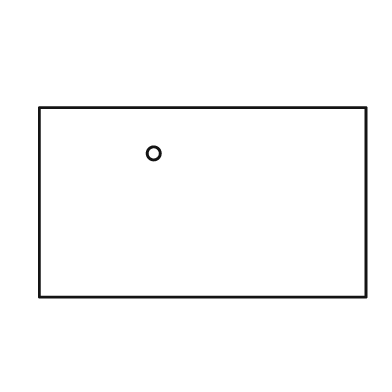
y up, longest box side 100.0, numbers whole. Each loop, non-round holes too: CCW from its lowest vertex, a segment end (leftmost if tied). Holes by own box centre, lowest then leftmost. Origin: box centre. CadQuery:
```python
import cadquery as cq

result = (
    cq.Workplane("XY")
    .moveTo(-50.0, -29.0)
    .lineTo(50.0, -29.0)
    .lineTo(50.0, 29.0)
    .lineTo(-50.0, 29.0)
    .close()
    .moveTo(-15.0, 15.0)
    .circle(2.0)
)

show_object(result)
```